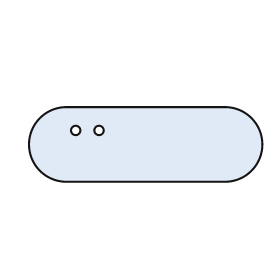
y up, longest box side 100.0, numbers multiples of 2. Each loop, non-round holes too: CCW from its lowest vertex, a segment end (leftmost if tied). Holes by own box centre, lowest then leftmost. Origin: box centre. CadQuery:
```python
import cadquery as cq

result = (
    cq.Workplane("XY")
    .moveTo(-34.0, -16.0)
    .lineTo(34.0, -16.0)
    .threePointArc((50.0, 0.0), (34.0, 16.0))
    .lineTo(-34.0, 16.0)
    .threePointArc((-50.0, 0.0), (-34.0, -16.0))
    .close()
    .moveTo(-30.0, 6.0)
    .circle(2.0)
    .moveTo(-20.0, 6.0)
    .circle(2.0)
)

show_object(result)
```